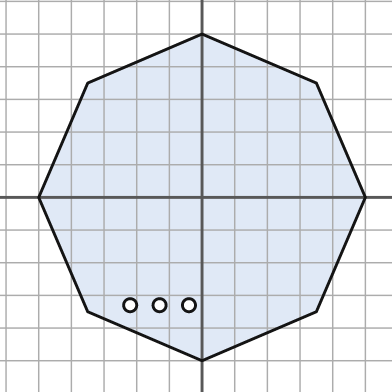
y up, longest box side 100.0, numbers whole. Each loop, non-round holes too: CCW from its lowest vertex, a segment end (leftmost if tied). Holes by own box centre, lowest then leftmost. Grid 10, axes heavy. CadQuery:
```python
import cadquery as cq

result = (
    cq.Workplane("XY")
    .moveTo(0.0, -50.0)
    .lineTo(35.0, -35.0)
    .lineTo(50.0, 0.0)
    .lineTo(35.0, 35.0)
    .lineTo(0.0, 50.0)
    .lineTo(-35.0, 35.0)
    .lineTo(-50.0, 0.0)
    .lineTo(-35.0, -35.0)
    .close()
    .moveTo(-22.0, -33.0)
    .circle(2.0)
    .moveTo(-13.0, -33.0)
    .circle(2.0)
    .moveTo(-4.0, -33.0)
    .circle(2.0)
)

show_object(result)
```